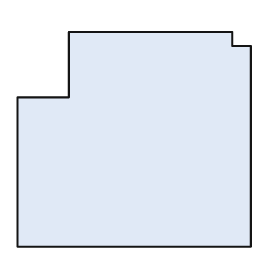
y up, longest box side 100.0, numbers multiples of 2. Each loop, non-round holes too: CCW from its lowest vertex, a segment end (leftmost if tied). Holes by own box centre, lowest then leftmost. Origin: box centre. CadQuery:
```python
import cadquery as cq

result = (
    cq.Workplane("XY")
    .moveTo(-50.0, -46.0)
    .lineTo(50.0, -46.0)
    .lineTo(50.0, 40.0)
    .lineTo(42.0, 40.0)
    .lineTo(42.0, 46.0)
    .lineTo(-28.0, 46.0)
    .lineTo(-28.0, 18.0)
    .lineTo(-50.0, 18.0)
    .close()
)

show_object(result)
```